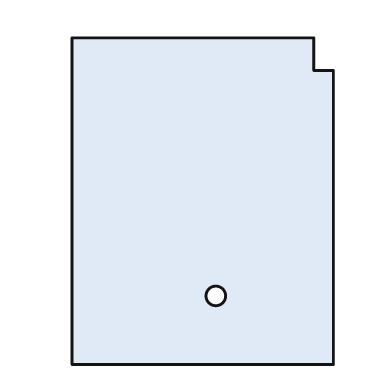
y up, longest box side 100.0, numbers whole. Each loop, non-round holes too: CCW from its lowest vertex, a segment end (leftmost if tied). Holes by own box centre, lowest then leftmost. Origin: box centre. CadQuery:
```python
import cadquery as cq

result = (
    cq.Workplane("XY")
    .moveTo(-40.0, -50.0)
    .lineTo(40.0, -50.0)
    .lineTo(40.0, 40.0)
    .lineTo(34.0, 40.0)
    .lineTo(34.0, 50.0)
    .lineTo(-40.0, 50.0)
    .close()
    .moveTo(4.0, -29.0)
    .circle(3.0)
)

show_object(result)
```